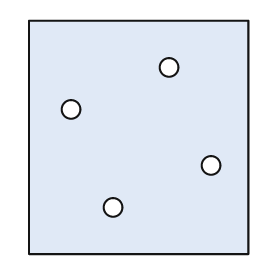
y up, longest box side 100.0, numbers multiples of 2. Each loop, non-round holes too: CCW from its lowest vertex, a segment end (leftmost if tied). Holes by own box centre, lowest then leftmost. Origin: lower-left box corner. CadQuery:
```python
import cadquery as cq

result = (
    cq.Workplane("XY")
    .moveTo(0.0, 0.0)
    .lineTo(94.0, 0.0)
    .lineTo(94.0, 100.0)
    .lineTo(0.0, 100.0)
    .close()
    .moveTo(36.0, 20.0)
    .circle(4.0)
    .moveTo(78.0, 38.0)
    .circle(4.0)
    .moveTo(18.0, 62.0)
    .circle(4.0)
    .moveTo(60.0, 80.0)
    .circle(4.0)
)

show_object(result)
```